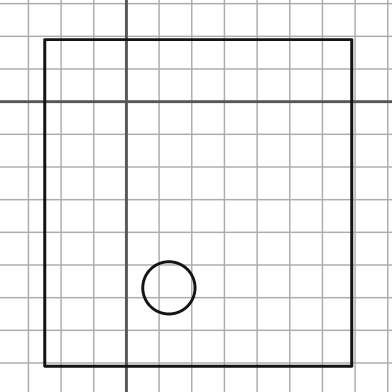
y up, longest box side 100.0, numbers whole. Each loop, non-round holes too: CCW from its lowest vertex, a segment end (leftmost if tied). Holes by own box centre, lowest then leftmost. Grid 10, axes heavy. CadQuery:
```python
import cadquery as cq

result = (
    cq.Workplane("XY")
    .moveTo(-25.0, -81.0)
    .lineTo(69.0, -81.0)
    .lineTo(69.0, 19.0)
    .lineTo(-25.0, 19.0)
    .close()
    .moveTo(13.0, -57.0)
    .circle(8.0)
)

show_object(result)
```